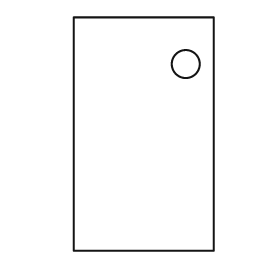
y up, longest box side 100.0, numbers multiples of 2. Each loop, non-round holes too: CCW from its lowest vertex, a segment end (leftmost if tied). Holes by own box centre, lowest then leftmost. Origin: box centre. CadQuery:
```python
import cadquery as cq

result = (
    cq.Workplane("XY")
    .moveTo(-30.0, -50.0)
    .lineTo(30.0, -50.0)
    .lineTo(30.0, 50.0)
    .lineTo(-30.0, 50.0)
    .close()
    .moveTo(18.0, 30.0)
    .circle(6.0)
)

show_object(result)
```